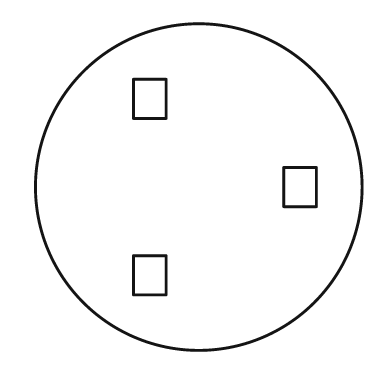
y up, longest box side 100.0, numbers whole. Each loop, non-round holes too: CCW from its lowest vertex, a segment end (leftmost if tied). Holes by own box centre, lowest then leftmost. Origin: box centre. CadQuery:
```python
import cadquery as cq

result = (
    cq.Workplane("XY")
    .moveTo(0.0, 0.0)
    .circle(50.0)
    .moveTo(-20.0, -33.0)
    .lineTo(-10.0, -33.0)
    .lineTo(-10.0, -21.0)
    .lineTo(-20.0, -21.0)
    .close()
    .moveTo(26.0, -6.0)
    .lineTo(36.0, -6.0)
    .lineTo(36.0, 6.0)
    .lineTo(26.0, 6.0)
    .close()
    .moveTo(-20.0, 21.0)
    .lineTo(-10.0, 21.0)
    .lineTo(-10.0, 33.0)
    .lineTo(-20.0, 33.0)
    .close()
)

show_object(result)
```